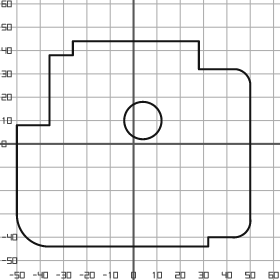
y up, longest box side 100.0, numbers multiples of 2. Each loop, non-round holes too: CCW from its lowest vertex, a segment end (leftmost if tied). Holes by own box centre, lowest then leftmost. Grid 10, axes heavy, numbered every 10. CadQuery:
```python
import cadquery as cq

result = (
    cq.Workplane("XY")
    .moveTo(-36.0, -44.0)
    .lineTo(32.0, -44.0)
    .lineTo(32.0, -40.0)
    .lineTo(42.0, -40.0)
    .threePointArc((48.0, -38.0), (50.0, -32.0))
    .lineTo(50.0, 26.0)
    .threePointArc((48.0, 30.0), (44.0, 32.0))
    .lineTo(28.0, 32.0)
    .lineTo(28.0, 44.0)
    .lineTo(-26.0, 44.0)
    .lineTo(-26.0, 38.0)
    .lineTo(-36.0, 38.0)
    .lineTo(-36.0, 8.0)
    .lineTo(-50.0, 8.0)
    .lineTo(-50.0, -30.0)
    .threePointArc((-46.0, -40.0), (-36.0, -44.0))
    .close()
    .moveTo(4.0, 10.0)
    .circle(8.0)
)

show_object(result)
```